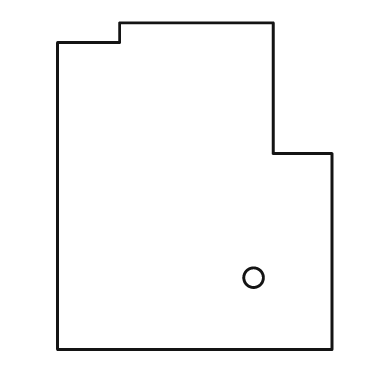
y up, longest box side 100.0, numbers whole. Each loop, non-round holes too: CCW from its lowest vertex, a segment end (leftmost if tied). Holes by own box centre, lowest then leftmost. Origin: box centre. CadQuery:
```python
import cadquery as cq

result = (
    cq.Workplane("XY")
    .moveTo(-42.0, -50.0)
    .lineTo(42.0, -50.0)
    .lineTo(42.0, 10.0)
    .lineTo(24.0, 10.0)
    .lineTo(24.0, 50.0)
    .lineTo(-23.0, 50.0)
    .lineTo(-23.0, 44.0)
    .lineTo(-42.0, 44.0)
    .close()
    .moveTo(18.0, -28.0)
    .circle(3.0)
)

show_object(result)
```